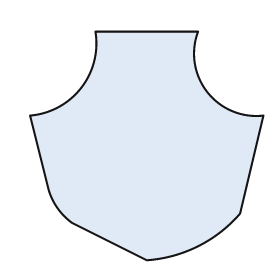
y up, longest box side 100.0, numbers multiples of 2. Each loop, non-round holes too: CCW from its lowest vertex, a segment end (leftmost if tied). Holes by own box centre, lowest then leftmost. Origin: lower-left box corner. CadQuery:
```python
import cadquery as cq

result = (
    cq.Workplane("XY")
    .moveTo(50.0, 0.0)
    .threePointArc((72.0, 6.0), (90.0, 20.0))
    .lineTo(100.0, 62.0)
    .threePointArc((76.0, 72.0), (72.0, 98.0))
    .lineTo(28.0, 98.0)
    .threePointArc((22.0, 74.0), (0.0, 62.0))
    .lineTo(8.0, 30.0)
    .threePointArc((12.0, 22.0), (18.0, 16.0))
    .close()
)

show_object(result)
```